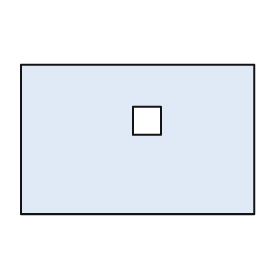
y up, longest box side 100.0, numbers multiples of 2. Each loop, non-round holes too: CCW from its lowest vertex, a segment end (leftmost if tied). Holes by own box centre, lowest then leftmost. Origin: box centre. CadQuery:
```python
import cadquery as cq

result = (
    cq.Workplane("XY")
    .moveTo(-50.0, -32.0)
    .lineTo(50.0, -32.0)
    .lineTo(50.0, 32.0)
    .lineTo(-50.0, 32.0)
    .close()
    .moveTo(-2.0, 2.0)
    .lineTo(10.0, 2.0)
    .lineTo(10.0, 14.0)
    .lineTo(-2.0, 14.0)
    .close()
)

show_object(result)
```